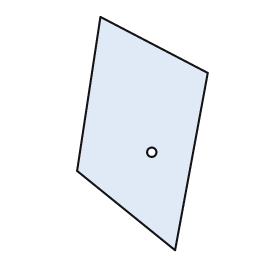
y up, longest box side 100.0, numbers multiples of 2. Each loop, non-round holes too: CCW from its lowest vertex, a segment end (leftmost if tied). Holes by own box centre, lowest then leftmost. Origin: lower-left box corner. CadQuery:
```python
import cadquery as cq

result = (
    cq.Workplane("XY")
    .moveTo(42.0, 0.0)
    .lineTo(56.0, 76.0)
    .lineTo(10.0, 100.0)
    .lineTo(0.0, 34.0)
    .close()
    .moveTo(32.0, 42.0)
    .circle(2.0)
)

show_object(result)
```